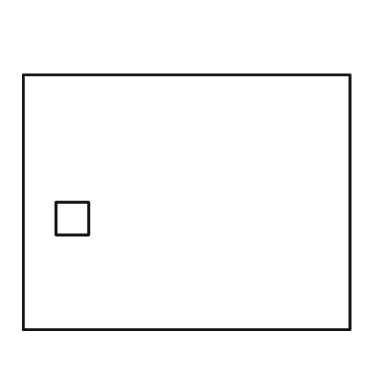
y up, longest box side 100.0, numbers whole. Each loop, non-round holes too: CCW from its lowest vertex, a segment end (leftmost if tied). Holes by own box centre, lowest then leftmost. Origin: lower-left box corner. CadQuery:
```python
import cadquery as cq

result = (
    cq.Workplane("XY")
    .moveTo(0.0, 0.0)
    .lineTo(100.0, 0.0)
    .lineTo(100.0, 78.0)
    .lineTo(0.0, 78.0)
    .close()
    .moveTo(10.0, 29.0)
    .lineTo(20.0, 29.0)
    .lineTo(20.0, 39.0)
    .lineTo(10.0, 39.0)
    .close()
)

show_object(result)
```